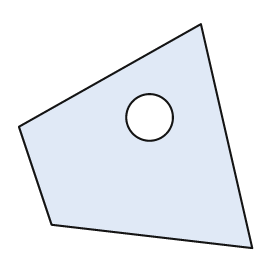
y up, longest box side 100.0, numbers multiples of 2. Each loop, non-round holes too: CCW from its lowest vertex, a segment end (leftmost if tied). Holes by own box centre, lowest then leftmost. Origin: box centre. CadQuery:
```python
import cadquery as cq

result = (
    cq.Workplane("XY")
    .moveTo(50.0, -48.0)
    .lineTo(28.0, 48.0)
    .lineTo(-50.0, 4.0)
    .lineTo(-36.0, -38.0)
    .close()
    .moveTo(6.0, 8.0)
    .circle(10.0)
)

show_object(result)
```